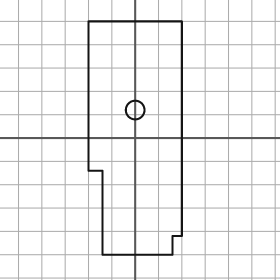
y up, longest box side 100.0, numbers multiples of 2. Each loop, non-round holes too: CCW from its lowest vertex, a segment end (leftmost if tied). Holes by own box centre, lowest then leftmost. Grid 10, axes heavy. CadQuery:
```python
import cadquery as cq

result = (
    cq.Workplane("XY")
    .moveTo(-14.0, -50.0)
    .lineTo(16.0, -50.0)
    .lineTo(16.0, -42.0)
    .lineTo(20.0, -42.0)
    .lineTo(20.0, 50.0)
    .lineTo(-20.0, 50.0)
    .lineTo(-20.0, -14.0)
    .lineTo(-14.0, -14.0)
    .close()
    .moveTo(0.0, 12.0)
    .circle(4.0)
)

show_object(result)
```